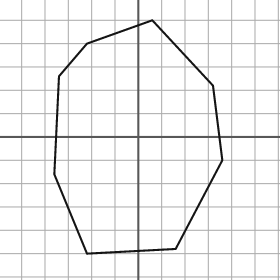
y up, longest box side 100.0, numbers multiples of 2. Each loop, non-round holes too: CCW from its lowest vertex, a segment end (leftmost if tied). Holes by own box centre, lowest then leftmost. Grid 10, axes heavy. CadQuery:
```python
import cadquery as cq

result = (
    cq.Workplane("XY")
    .moveTo(-22.0, -50.0)
    .lineTo(16.0, -48.0)
    .lineTo(36.0, -10.0)
    .lineTo(32.0, 22.0)
    .lineTo(6.0, 50.0)
    .lineTo(-22.0, 40.0)
    .lineTo(-34.0, 26.0)
    .lineTo(-36.0, -16.0)
    .close()
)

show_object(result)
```